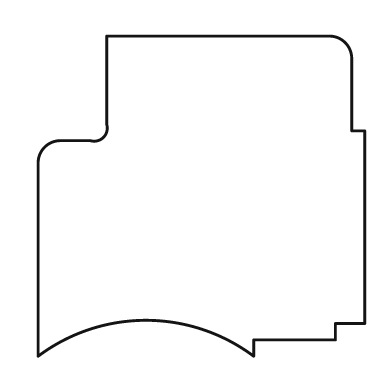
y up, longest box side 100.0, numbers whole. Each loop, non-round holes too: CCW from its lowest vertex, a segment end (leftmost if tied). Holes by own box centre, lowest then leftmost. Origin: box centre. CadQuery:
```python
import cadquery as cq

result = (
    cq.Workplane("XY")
    .moveTo(-50.0, -49.0)
    .threePointArc((-17.0, -38.0), (16.0, -49.0))
    .lineTo(16.0, -44.0)
    .lineTo(41.0, -44.0)
    .lineTo(41.0, -39.0)
    .lineTo(50.0, -39.0)
    .lineTo(50.0, 20.0)
    .lineTo(46.0, 20.0)
    .lineTo(46.0, 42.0)
    .threePointArc((44.0, 47.0), (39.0, 49.0))
    .lineTo(-29.0, 49.0)
    .lineTo(-29.0, 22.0)
    .threePointArc((-30.0, 18.0), (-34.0, 17.0))
    .lineTo(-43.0, 17.0)
    .threePointArc((-48.0, 15.0), (-50.0, 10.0))
    .close()
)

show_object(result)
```